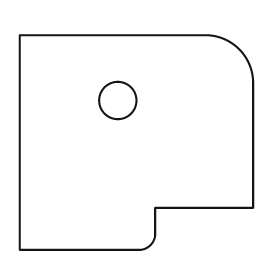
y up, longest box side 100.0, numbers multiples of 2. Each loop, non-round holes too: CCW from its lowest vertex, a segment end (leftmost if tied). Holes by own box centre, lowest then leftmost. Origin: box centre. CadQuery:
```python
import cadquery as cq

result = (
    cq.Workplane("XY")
    .moveTo(-50.0, -46.0)
    .lineTo(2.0, -46.0)
    .threePointArc((6.0, -44.0), (8.0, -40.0))
    .lineTo(8.0, -28.0)
    .lineTo(50.0, -28.0)
    .lineTo(50.0, 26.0)
    .threePointArc((44.0, 40.0), (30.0, 46.0))
    .lineTo(-50.0, 46.0)
    .close()
    .moveTo(-8.0, 18.0)
    .circle(8.0)
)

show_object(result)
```